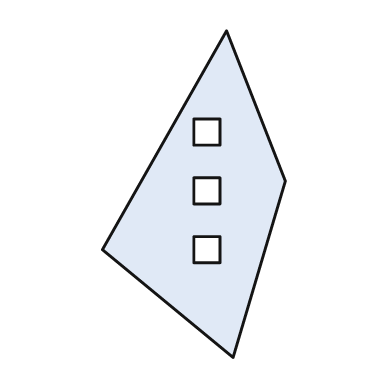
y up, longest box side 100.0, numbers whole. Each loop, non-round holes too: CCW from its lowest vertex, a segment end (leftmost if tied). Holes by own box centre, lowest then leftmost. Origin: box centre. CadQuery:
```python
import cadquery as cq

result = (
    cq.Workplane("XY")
    .moveTo(12.0, -50.0)
    .lineTo(28.0, 4.0)
    .lineTo(10.0, 50.0)
    .lineTo(-28.0, -17.0)
    .close()
    .moveTo(0.0, -21.0)
    .lineTo(8.0, -21.0)
    .lineTo(8.0, -13.0)
    .lineTo(0.0, -13.0)
    .close()
    .moveTo(0.0, -3.0)
    .lineTo(8.0, -3.0)
    .lineTo(8.0, 5.0)
    .lineTo(0.0, 5.0)
    .close()
    .moveTo(0.0, 15.0)
    .lineTo(8.0, 15.0)
    .lineTo(8.0, 23.0)
    .lineTo(0.0, 23.0)
    .close()
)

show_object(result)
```